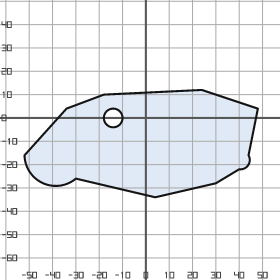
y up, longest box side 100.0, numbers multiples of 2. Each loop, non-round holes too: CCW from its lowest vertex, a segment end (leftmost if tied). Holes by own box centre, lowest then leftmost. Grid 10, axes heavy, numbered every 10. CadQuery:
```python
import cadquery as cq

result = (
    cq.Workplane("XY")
    .moveTo(4.0, -34.0)
    .lineTo(30.0, -28.0)
    .lineTo(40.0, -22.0)
    .threePointArc((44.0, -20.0), (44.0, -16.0))
    .lineTo(48.0, 4.0)
    .lineTo(24.0, 12.0)
    .lineTo(-18.0, 10.0)
    .lineTo(-34.0, 4.0)
    .lineTo(-52.0, -16.0)
    .threePointArc((-44.0, -28.0), (-30.0, -26.0))
    .close()
    .moveTo(-14.0, 0.0)
    .circle(4.0)
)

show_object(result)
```